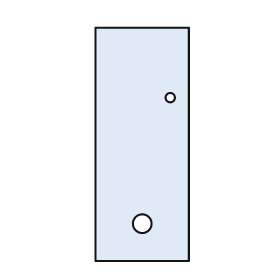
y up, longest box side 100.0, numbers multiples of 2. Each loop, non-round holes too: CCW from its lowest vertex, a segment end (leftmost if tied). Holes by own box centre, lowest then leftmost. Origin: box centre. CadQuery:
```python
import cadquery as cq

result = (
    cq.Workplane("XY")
    .moveTo(-20.0, -50.0)
    .lineTo(20.0, -50.0)
    .lineTo(20.0, 50.0)
    .lineTo(-20.0, 50.0)
    .close()
    .moveTo(0.0, -34.0)
    .circle(4.0)
    .moveTo(12.0, 20.0)
    .circle(2.0)
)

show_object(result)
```